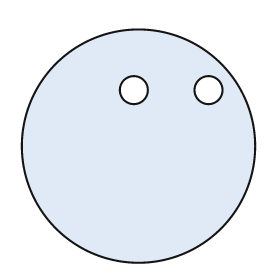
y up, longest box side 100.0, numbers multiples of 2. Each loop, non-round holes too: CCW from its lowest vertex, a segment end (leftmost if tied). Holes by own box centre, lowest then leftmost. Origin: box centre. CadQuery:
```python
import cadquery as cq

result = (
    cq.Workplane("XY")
    .moveTo(0.0, 0.0)
    .circle(50.0)
    .moveTo(-2.0, 24.0)
    .circle(6.0)
    .moveTo(30.0, 24.0)
    .circle(6.0)
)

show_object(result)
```